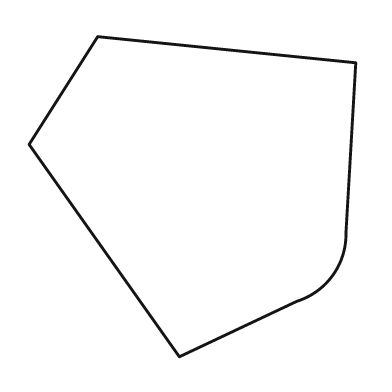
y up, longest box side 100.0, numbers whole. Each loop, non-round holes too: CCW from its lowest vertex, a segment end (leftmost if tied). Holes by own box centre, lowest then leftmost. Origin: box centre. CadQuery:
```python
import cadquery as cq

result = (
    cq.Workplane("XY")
    .moveTo(-4.0, -49.0)
    .lineTo(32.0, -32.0)
    .threePointArc((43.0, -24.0), (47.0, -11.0))
    .lineTo(50.0, 41.0)
    .lineTo(-29.0, 49.0)
    .lineTo(-50.0, 16.0)
    .close()
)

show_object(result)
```